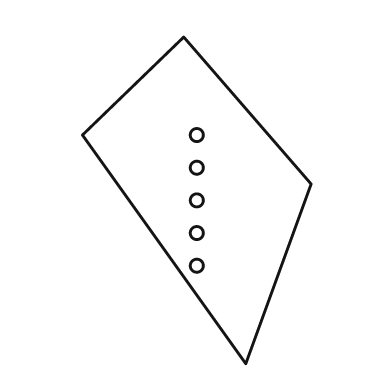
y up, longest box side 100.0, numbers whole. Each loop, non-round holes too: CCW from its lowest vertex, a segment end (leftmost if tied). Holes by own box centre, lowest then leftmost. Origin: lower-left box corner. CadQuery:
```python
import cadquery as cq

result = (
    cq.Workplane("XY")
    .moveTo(50.0, 0.0)
    .lineTo(70.0, 55.0)
    .lineTo(31.0, 100.0)
    .lineTo(0.0, 70.0)
    .close()
    .moveTo(35.0, 30.0)
    .circle(2.0)
    .moveTo(35.0, 40.0)
    .circle(2.0)
    .moveTo(35.0, 50.0)
    .circle(2.0)
    .moveTo(35.0, 60.0)
    .circle(2.0)
    .moveTo(35.0, 70.0)
    .circle(2.0)
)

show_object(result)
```